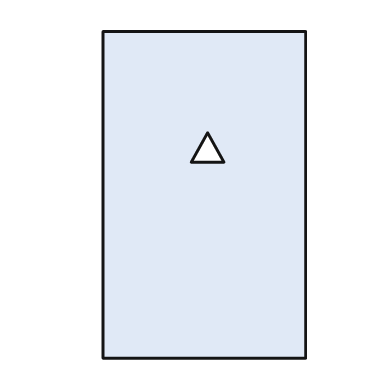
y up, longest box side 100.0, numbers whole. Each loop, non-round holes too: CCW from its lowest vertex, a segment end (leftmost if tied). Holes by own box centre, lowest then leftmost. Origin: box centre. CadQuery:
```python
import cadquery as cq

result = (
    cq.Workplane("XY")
    .moveTo(-31.0, -50.0)
    .lineTo(31.0, -50.0)
    .lineTo(31.0, 50.0)
    .lineTo(-31.0, 50.0)
    .close()
    .moveTo(-4.0, 10.0)
    .lineTo(6.0, 10.0)
    .lineTo(1.0, 19.0)
    .close()
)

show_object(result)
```